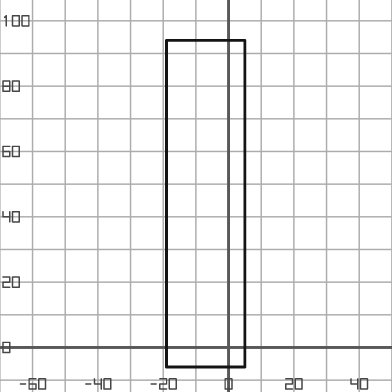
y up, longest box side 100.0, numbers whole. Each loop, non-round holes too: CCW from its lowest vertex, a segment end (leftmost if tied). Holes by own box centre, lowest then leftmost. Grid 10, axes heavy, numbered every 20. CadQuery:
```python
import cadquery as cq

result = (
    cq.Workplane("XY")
    .moveTo(-19.0, -6.0)
    .lineTo(5.0, -6.0)
    .lineTo(5.0, 94.0)
    .lineTo(-19.0, 94.0)
    .close()
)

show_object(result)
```